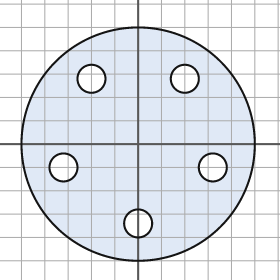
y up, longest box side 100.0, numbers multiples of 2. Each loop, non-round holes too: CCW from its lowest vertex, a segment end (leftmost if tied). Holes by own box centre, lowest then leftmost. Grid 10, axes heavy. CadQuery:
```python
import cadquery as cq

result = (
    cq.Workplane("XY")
    .moveTo(0.0, 0.0)
    .circle(50.0)
    .moveTo(0.0, -34.0)
    .circle(6.0)
    .moveTo(-32.0, -10.0)
    .circle(6.0)
    .moveTo(32.0, -10.0)
    .circle(6.0)
    .moveTo(-20.0, 28.0)
    .circle(6.0)
    .moveTo(20.0, 28.0)
    .circle(6.0)
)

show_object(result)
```